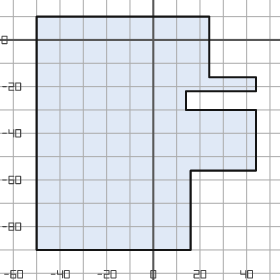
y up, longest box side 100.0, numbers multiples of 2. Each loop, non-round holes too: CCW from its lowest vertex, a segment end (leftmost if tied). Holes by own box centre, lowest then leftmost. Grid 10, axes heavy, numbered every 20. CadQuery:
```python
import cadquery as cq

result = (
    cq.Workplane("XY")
    .moveTo(-50.0, -90.0)
    .lineTo(16.0, -90.0)
    .lineTo(16.0, -56.0)
    .lineTo(44.0, -56.0)
    .lineTo(44.0, -30.0)
    .lineTo(14.0, -30.0)
    .lineTo(14.0, -22.0)
    .lineTo(44.0, -22.0)
    .lineTo(44.0, -16.0)
    .lineTo(24.0, -16.0)
    .lineTo(24.0, 10.0)
    .lineTo(-50.0, 10.0)
    .close()
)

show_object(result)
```